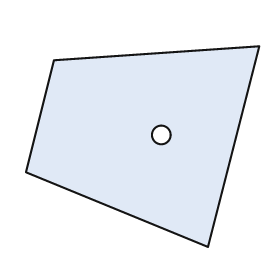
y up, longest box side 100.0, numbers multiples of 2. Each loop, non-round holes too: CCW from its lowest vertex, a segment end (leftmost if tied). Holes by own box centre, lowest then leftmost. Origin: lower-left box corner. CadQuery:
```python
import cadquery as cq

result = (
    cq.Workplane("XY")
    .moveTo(78.0, 0.0)
    .lineTo(100.0, 86.0)
    .lineTo(12.0, 80.0)
    .lineTo(0.0, 32.0)
    .close()
    .moveTo(58.0, 48.0)
    .circle(4.0)
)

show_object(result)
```